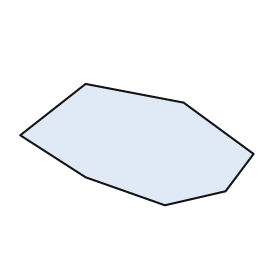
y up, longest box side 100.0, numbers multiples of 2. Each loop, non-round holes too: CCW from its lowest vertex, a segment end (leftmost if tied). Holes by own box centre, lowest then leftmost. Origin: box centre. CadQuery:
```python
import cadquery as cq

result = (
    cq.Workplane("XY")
    .moveTo(12.0, -26.0)
    .lineTo(38.0, -20.0)
    .lineTo(50.0, -4.0)
    .lineTo(20.0, 18.0)
    .lineTo(-22.0, 26.0)
    .lineTo(-50.0, 4.0)
    .lineTo(-22.0, -14.0)
    .close()
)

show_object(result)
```